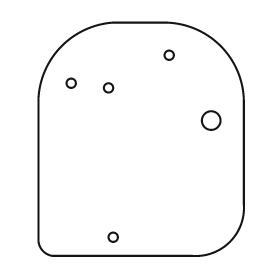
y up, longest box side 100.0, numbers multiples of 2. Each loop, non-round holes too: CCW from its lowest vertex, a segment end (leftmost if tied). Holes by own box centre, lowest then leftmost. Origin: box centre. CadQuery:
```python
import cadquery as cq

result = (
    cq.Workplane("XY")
    .moveTo(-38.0, -50.0)
    .lineTo(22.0, -50.0)
    .threePointArc((38.0, -44.0), (44.0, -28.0))
    .lineTo(44.0, 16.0)
    .threePointArc((34.0, 40.0), (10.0, 50.0))
    .lineTo(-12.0, 50.0)
    .threePointArc((-34.0, 40.0), (-44.0, 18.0))
    .lineTo(-44.0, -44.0)
    .threePointArc((-42.0, -48.0), (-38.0, -50.0))
    .close()
    .moveTo(-12.0, -42.0)
    .circle(2.0)
    .moveTo(30.0, 8.0)
    .circle(4.0)
    .moveTo(-14.0, 22.0)
    .circle(2.0)
    .moveTo(-30.0, 24.0)
    .circle(2.0)
    .moveTo(12.0, 36.0)
    .circle(2.0)
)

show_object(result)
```